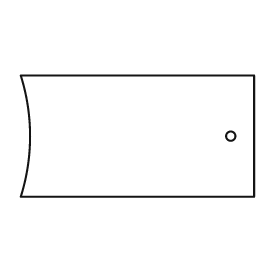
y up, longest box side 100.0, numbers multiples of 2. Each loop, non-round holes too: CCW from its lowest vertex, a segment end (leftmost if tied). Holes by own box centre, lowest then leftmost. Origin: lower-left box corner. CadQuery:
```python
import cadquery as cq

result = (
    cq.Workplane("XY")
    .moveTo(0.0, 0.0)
    .lineTo(100.0, 0.0)
    .lineTo(100.0, 52.0)
    .lineTo(0.0, 52.0)
    .threePointArc((4.0, 26.0), (0.0, 0.0))
    .close()
    .moveTo(90.0, 26.0)
    .circle(2.0)
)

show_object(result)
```